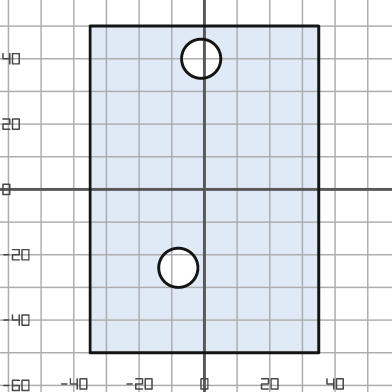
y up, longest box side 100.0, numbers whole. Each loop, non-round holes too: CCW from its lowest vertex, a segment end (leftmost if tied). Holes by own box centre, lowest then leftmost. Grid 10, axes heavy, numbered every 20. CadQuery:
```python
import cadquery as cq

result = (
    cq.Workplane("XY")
    .moveTo(-35.0, -50.0)
    .lineTo(35.0, -50.0)
    .lineTo(35.0, 50.0)
    .lineTo(-35.0, 50.0)
    .close()
    .moveTo(-8.0, -24.0)
    .circle(6.0)
    .moveTo(-1.0, 40.0)
    .circle(6.0)
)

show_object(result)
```